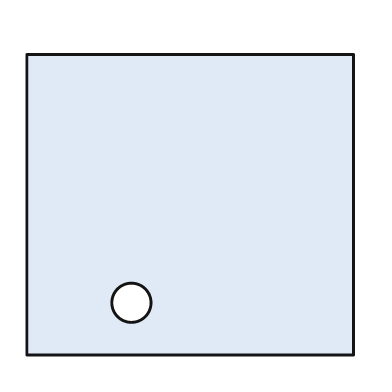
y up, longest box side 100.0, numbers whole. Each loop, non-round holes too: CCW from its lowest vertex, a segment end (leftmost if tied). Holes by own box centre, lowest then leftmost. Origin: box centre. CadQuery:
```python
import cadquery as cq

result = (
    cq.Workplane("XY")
    .moveTo(-50.0, -46.0)
    .lineTo(50.0, -46.0)
    .lineTo(50.0, 46.0)
    .lineTo(-50.0, 46.0)
    .close()
    .moveTo(-18.0, -30.0)
    .circle(6.0)
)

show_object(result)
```